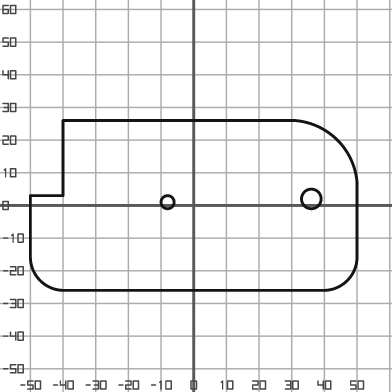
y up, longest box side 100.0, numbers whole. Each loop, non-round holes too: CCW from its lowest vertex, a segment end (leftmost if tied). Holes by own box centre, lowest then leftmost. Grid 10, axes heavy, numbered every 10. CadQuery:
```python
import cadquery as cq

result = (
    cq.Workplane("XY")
    .moveTo(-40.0, -26.0)
    .lineTo(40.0, -26.0)
    .threePointArc((47.0, -23.0), (50.0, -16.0))
    .lineTo(50.0, 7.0)
    .threePointArc((44.0, 20.0), (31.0, 26.0))
    .lineTo(-40.0, 26.0)
    .lineTo(-40.0, 3.0)
    .lineTo(-50.0, 3.0)
    .lineTo(-50.0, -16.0)
    .threePointArc((-47.0, -23.0), (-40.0, -26.0))
    .close()
    .moveTo(-8.0, 1.0)
    .circle(2.0)
    .moveTo(36.0, 2.0)
    .circle(3.0)
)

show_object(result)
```